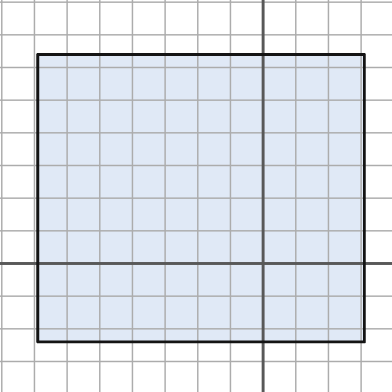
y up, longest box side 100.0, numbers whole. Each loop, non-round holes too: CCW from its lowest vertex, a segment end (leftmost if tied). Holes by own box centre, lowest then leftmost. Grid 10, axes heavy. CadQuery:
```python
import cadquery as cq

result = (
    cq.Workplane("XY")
    .moveTo(-69.0, -24.0)
    .lineTo(31.0, -24.0)
    .lineTo(31.0, 64.0)
    .lineTo(-69.0, 64.0)
    .close()
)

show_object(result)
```